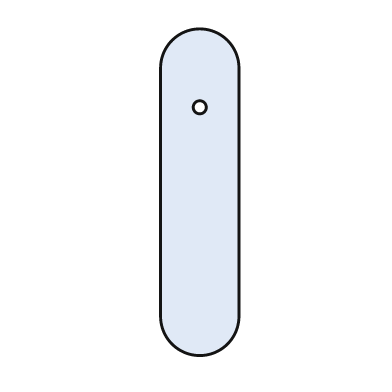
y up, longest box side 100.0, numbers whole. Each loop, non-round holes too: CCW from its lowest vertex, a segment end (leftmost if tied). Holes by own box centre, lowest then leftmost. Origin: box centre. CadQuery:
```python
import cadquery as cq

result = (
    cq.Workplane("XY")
    .moveTo(-12.0, -38.0)
    .threePointArc((0.0, -50.0), (12.0, -38.0))
    .lineTo(12.0, 38.0)
    .threePointArc((0.0, 50.0), (-12.0, 38.0))
    .close()
    .moveTo(0.0, 26.0)
    .circle(2.0)
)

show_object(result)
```